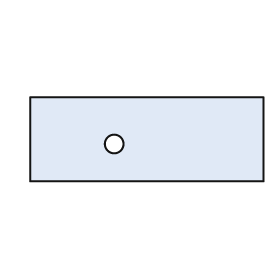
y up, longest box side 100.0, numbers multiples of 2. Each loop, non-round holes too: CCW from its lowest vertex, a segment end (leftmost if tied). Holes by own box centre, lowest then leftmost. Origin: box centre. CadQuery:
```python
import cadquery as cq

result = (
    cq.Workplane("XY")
    .moveTo(-50.0, -18.0)
    .lineTo(50.0, -18.0)
    .lineTo(50.0, 18.0)
    .lineTo(-50.0, 18.0)
    .close()
    .moveTo(-14.0, -2.0)
    .circle(4.0)
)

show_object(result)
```